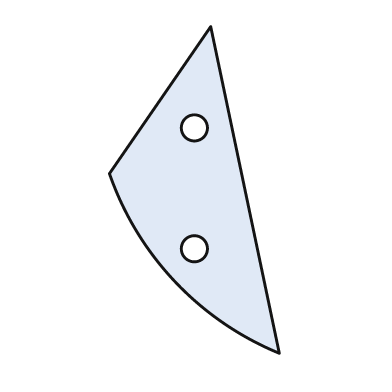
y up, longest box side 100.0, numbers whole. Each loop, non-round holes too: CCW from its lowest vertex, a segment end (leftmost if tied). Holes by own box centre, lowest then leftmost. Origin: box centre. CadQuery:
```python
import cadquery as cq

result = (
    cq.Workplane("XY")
    .moveTo(26.0, -50.0)
    .lineTo(5.0, 50.0)
    .lineTo(-26.0, 5.0)
    .threePointArc((-6.0, -28.0), (26.0, -50.0))
    .close()
    .moveTo(0.0, -18.0)
    .circle(4.0)
    .moveTo(0.0, 19.0)
    .circle(4.0)
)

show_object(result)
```